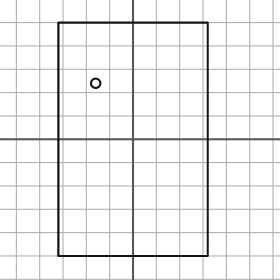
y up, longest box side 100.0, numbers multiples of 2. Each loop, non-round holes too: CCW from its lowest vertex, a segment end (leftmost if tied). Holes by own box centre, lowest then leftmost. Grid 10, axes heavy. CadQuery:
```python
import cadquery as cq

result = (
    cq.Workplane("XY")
    .moveTo(-32.0, -50.0)
    .lineTo(32.0, -50.0)
    .lineTo(32.0, 50.0)
    .lineTo(-32.0, 50.0)
    .close()
    .moveTo(-16.0, 24.0)
    .circle(2.0)
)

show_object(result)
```